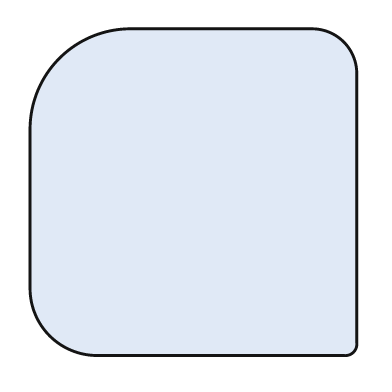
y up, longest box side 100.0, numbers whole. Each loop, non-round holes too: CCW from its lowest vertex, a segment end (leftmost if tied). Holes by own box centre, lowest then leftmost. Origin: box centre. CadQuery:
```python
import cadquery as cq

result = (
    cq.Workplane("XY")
    .moveTo(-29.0, -50.0)
    .lineTo(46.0, -50.0)
    .threePointArc((49.0, -49.0), (50.0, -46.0))
    .lineTo(50.0, 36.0)
    .threePointArc((46.0, 46.0), (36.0, 50.0))
    .lineTo(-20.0, 50.0)
    .threePointArc((-41.0, 41.0), (-50.0, 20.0))
    .lineTo(-50.0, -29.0)
    .threePointArc((-44.0, -44.0), (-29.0, -50.0))
    .close()
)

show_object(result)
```